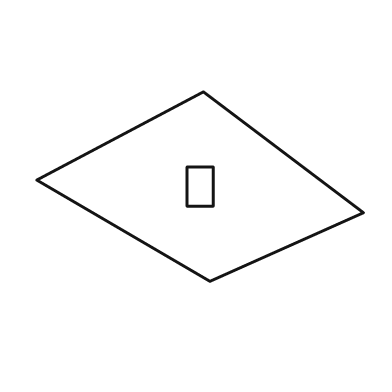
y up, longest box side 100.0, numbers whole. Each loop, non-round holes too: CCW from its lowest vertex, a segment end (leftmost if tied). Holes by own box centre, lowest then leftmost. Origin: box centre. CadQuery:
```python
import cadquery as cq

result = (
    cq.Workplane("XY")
    .moveTo(3.0, -29.0)
    .lineTo(50.0, -8.0)
    .lineTo(1.0, 29.0)
    .lineTo(-50.0, 2.0)
    .close()
    .moveTo(-4.0, -6.0)
    .lineTo(4.0, -6.0)
    .lineTo(4.0, 6.0)
    .lineTo(-4.0, 6.0)
    .close()
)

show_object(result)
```